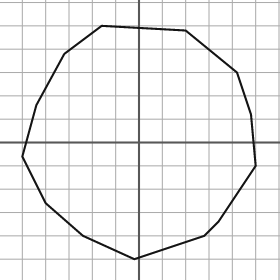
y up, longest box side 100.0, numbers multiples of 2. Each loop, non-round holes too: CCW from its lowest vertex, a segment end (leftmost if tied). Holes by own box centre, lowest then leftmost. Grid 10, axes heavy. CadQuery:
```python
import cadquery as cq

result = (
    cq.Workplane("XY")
    .moveTo(-2.0, -50.0)
    .lineTo(28.0, -40.0)
    .lineTo(34.0, -34.0)
    .lineTo(50.0, -10.0)
    .lineTo(48.0, 12.0)
    .lineTo(42.0, 30.0)
    .lineTo(20.0, 48.0)
    .lineTo(-16.0, 50.0)
    .lineTo(-32.0, 38.0)
    .lineTo(-44.0, 16.0)
    .lineTo(-50.0, -6.0)
    .lineTo(-40.0, -26.0)
    .lineTo(-24.0, -40.0)
    .close()
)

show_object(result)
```